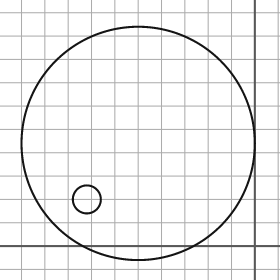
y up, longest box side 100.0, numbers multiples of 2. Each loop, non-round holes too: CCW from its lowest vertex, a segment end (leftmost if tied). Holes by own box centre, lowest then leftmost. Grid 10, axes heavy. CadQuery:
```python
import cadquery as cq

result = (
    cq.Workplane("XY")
    .moveTo(-50.0, 44.0)
    .circle(50.0)
    .moveTo(-72.0, 20.0)
    .circle(6.0)
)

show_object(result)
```